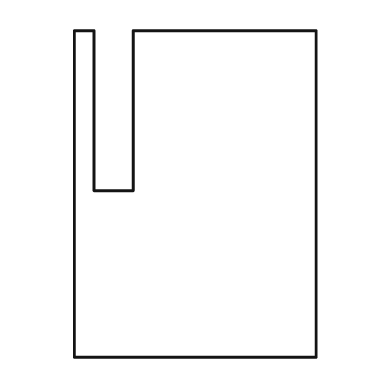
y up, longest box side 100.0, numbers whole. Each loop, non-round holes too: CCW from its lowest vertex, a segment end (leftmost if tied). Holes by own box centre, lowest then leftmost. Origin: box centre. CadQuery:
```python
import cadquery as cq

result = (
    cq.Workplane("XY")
    .moveTo(-37.0, -50.0)
    .lineTo(37.0, -50.0)
    .lineTo(37.0, 50.0)
    .lineTo(-19.0, 50.0)
    .lineTo(-19.0, 1.0)
    .lineTo(-31.0, 1.0)
    .lineTo(-31.0, 50.0)
    .lineTo(-37.0, 50.0)
    .close()
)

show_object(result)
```